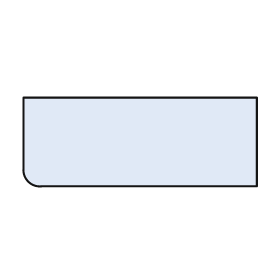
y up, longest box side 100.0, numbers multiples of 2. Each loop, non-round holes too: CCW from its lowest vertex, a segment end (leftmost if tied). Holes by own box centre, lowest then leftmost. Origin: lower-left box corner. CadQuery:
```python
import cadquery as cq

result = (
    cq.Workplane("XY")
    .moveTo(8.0, 0.0)
    .lineTo(100.0, 0.0)
    .lineTo(100.0, 38.0)
    .lineTo(0.0, 38.0)
    .lineTo(0.0, 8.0)
    .threePointArc((2.0, 2.0), (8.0, 0.0))
    .close()
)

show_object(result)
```